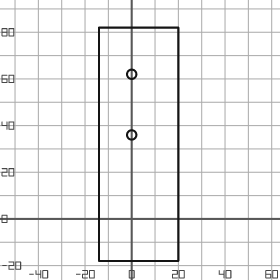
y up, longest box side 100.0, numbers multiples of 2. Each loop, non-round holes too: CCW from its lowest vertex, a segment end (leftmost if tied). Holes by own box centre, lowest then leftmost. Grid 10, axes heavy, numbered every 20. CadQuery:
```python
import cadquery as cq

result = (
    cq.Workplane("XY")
    .moveTo(-14.0, -18.0)
    .lineTo(20.0, -18.0)
    .lineTo(20.0, 82.0)
    .lineTo(-14.0, 82.0)
    .close()
    .moveTo(0.0, 36.0)
    .circle(2.0)
    .moveTo(0.0, 62.0)
    .circle(2.0)
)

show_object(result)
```